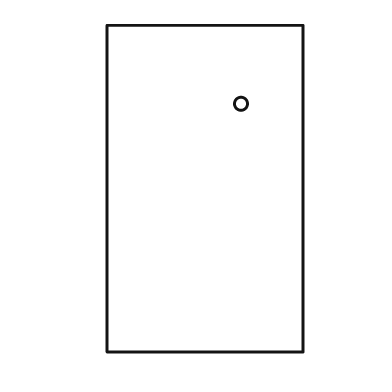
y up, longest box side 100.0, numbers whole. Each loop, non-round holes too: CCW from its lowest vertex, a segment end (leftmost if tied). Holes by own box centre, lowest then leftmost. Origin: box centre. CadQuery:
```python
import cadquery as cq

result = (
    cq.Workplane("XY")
    .moveTo(-30.0, -50.0)
    .lineTo(30.0, -50.0)
    .lineTo(30.0, 50.0)
    .lineTo(-30.0, 50.0)
    .close()
    .moveTo(11.0, 26.0)
    .circle(2.0)
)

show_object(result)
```